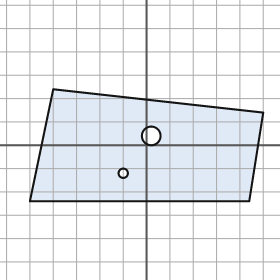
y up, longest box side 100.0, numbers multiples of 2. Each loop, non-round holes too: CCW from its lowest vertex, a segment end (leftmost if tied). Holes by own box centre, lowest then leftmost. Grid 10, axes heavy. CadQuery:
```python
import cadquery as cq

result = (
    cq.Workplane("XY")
    .moveTo(-50.0, -24.0)
    .lineTo(44.0, -24.0)
    .lineTo(50.0, 14.0)
    .lineTo(-40.0, 24.0)
    .close()
    .moveTo(-10.0, -12.0)
    .circle(2.0)
    .moveTo(2.0, 4.0)
    .circle(4.0)
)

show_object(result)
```